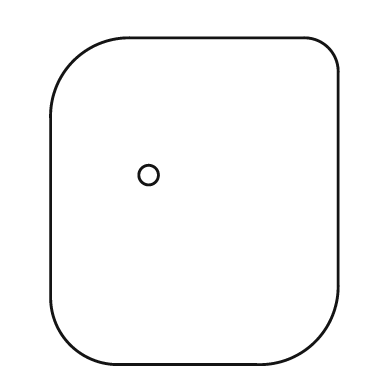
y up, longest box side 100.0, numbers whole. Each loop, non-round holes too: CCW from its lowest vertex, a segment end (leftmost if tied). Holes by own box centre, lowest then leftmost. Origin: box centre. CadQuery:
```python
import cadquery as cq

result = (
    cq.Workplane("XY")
    .moveTo(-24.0, -50.0)
    .lineTo(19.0, -50.0)
    .threePointArc((37.0, -43.0), (44.0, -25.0))
    .lineTo(44.0, 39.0)
    .threePointArc((41.0, 47.0), (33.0, 50.0))
    .lineTo(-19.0, 50.0)
    .threePointArc((-37.0, 43.0), (-44.0, 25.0))
    .lineTo(-44.0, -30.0)
    .threePointArc((-38.0, -44.0), (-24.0, -50.0))
    .close()
    .moveTo(-14.0, 8.0)
    .circle(3.0)
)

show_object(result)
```